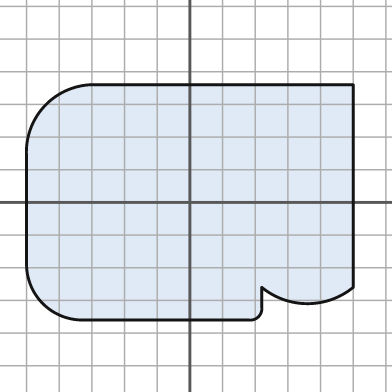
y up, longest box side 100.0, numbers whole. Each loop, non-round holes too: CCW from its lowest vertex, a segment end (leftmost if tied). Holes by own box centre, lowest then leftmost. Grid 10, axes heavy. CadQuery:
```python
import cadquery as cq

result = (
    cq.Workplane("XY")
    .moveTo(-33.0, -36.0)
    .lineTo(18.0, -36.0)
    .threePointArc((21.0, -35.0), (22.0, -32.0))
    .lineTo(22.0, -26.0)
    .threePointArc((36.0, -31.0), (50.0, -26.0))
    .lineTo(50.0, 36.0)
    .lineTo(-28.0, 36.0)
    .threePointArc((-44.0, 30.0), (-50.0, 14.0))
    .lineTo(-50.0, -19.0)
    .threePointArc((-45.0, -31.0), (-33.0, -36.0))
    .close()
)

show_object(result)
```